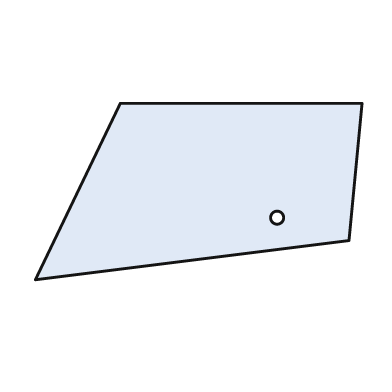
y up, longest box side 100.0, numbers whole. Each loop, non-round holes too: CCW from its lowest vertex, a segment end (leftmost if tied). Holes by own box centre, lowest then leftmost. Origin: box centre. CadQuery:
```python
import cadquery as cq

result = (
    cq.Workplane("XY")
    .moveTo(-50.0, -27.0)
    .lineTo(46.0, -15.0)
    .lineTo(50.0, 27.0)
    .lineTo(-24.0, 27.0)
    .close()
    .moveTo(24.0, -8.0)
    .circle(2.0)
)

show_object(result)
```